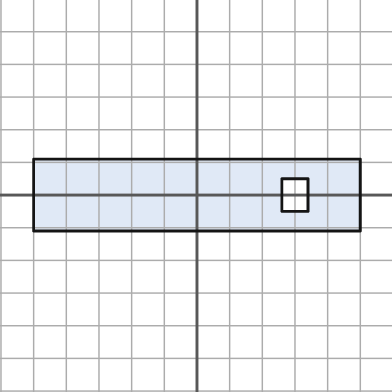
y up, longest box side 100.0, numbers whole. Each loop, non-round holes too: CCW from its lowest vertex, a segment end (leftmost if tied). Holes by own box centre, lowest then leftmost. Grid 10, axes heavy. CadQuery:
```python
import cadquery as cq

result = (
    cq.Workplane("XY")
    .moveTo(-50.0, -11.0)
    .lineTo(50.0, -11.0)
    .lineTo(50.0, 11.0)
    .lineTo(-50.0, 11.0)
    .close()
    .moveTo(26.0, -5.0)
    .lineTo(34.0, -5.0)
    .lineTo(34.0, 5.0)
    .lineTo(26.0, 5.0)
    .close()
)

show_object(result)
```